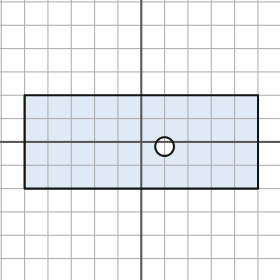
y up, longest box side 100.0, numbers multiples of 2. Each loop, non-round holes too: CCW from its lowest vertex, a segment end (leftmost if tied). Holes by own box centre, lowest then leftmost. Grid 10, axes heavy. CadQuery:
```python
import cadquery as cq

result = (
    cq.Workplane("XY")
    .moveTo(-50.0, -20.0)
    .lineTo(50.0, -20.0)
    .lineTo(50.0, 20.0)
    .lineTo(-50.0, 20.0)
    .close()
    .moveTo(10.0, -2.0)
    .circle(4.0)
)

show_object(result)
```